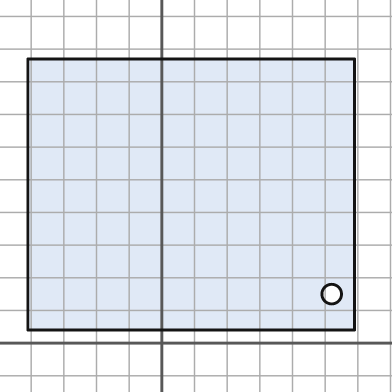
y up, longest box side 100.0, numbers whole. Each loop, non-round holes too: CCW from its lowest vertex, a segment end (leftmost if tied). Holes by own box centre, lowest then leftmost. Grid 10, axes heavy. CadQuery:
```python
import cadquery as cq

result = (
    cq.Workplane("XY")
    .moveTo(-41.0, 4.0)
    .lineTo(59.0, 4.0)
    .lineTo(59.0, 87.0)
    .lineTo(-41.0, 87.0)
    .close()
    .moveTo(52.0, 15.0)
    .circle(3.0)
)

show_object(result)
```